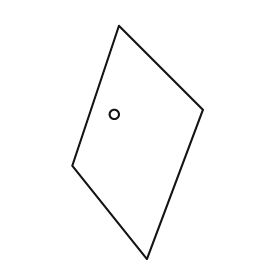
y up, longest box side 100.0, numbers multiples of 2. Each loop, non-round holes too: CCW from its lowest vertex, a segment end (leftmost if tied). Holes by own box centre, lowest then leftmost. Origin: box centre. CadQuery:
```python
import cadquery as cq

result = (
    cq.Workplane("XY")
    .moveTo(4.0, -50.0)
    .lineTo(28.0, 14.0)
    .lineTo(-8.0, 50.0)
    .lineTo(-28.0, -10.0)
    .close()
    .moveTo(-10.0, 12.0)
    .circle(2.0)
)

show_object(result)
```